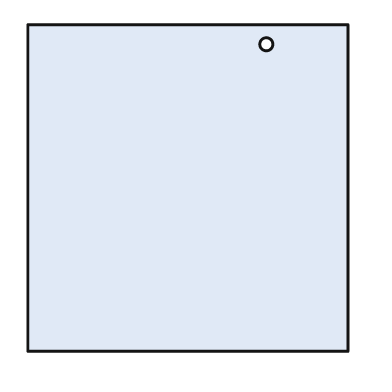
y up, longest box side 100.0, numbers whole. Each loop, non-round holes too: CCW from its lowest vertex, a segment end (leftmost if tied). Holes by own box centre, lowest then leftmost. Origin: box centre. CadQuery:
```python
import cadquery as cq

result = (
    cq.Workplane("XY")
    .moveTo(-49.0, -50.0)
    .lineTo(49.0, -50.0)
    .lineTo(49.0, 50.0)
    .lineTo(-49.0, 50.0)
    .close()
    .moveTo(24.0, 44.0)
    .circle(2.0)
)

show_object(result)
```